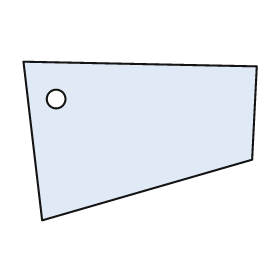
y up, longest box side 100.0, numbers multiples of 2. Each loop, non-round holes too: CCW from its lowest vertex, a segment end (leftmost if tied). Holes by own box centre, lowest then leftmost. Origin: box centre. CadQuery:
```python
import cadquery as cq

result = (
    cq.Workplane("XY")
    .moveTo(-42.0, -34.0)
    .lineTo(48.0, -8.0)
    .lineTo(50.0, 32.0)
    .lineTo(-50.0, 34.0)
    .close()
    .moveTo(-36.0, 18.0)
    .circle(4.0)
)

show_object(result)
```